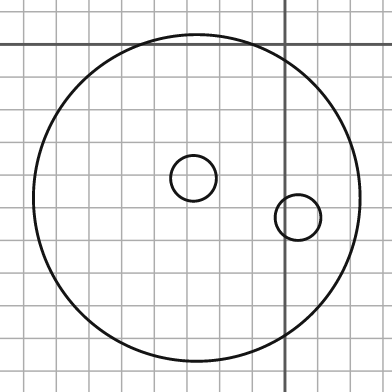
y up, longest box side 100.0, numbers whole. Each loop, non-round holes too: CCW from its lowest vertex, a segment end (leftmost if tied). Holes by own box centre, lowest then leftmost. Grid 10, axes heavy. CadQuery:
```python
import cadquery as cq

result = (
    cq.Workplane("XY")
    .moveTo(-27.0, -47.0)
    .circle(50.0)
    .moveTo(4.0, -53.0)
    .circle(7.0)
    .moveTo(-28.0, -41.0)
    .circle(7.0)
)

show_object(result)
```